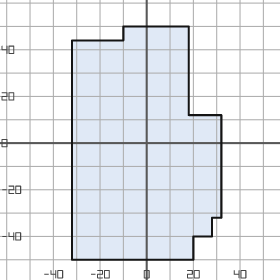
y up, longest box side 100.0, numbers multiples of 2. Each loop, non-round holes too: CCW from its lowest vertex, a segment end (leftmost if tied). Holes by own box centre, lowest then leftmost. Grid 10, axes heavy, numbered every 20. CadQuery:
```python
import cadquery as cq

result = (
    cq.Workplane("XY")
    .moveTo(-32.0, -50.0)
    .lineTo(20.0, -50.0)
    .lineTo(20.0, -40.0)
    .lineTo(28.0, -40.0)
    .lineTo(28.0, -32.0)
    .lineTo(32.0, -32.0)
    .lineTo(32.0, 12.0)
    .lineTo(18.0, 12.0)
    .lineTo(18.0, 50.0)
    .lineTo(-10.0, 50.0)
    .lineTo(-10.0, 44.0)
    .lineTo(-32.0, 44.0)
    .close()
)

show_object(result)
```